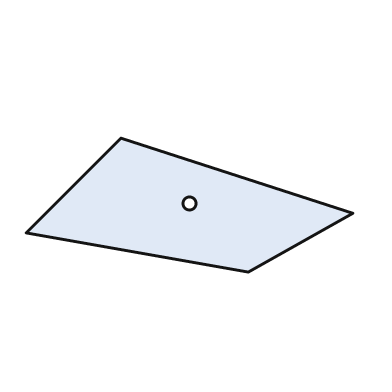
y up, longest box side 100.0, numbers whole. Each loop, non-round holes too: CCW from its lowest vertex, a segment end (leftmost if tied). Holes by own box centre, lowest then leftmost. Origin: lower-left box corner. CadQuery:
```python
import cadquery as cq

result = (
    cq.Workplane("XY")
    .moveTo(68.0, 0.0)
    .lineTo(100.0, 18.0)
    .lineTo(29.0, 41.0)
    .lineTo(0.0, 12.0)
    .close()
    .moveTo(50.0, 21.0)
    .circle(2.0)
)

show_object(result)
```